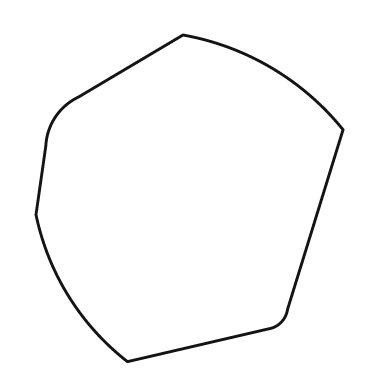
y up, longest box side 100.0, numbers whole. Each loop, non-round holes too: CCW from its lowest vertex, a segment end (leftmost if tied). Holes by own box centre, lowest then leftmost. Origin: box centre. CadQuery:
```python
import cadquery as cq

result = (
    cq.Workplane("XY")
    .moveTo(-19.0, -50.0)
    .lineTo(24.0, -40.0)
    .threePointArc((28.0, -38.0), (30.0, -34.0))
    .lineTo(47.0, 21.0)
    .threePointArc((25.0, 40.0), (-2.0, 50.0))
    .lineTo(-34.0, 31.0)
    .threePointArc((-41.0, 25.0), (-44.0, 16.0))
    .lineTo(-47.0, -5.0)
    .threePointArc((-37.0, -30.0), (-19.0, -50.0))
    .close()
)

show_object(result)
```